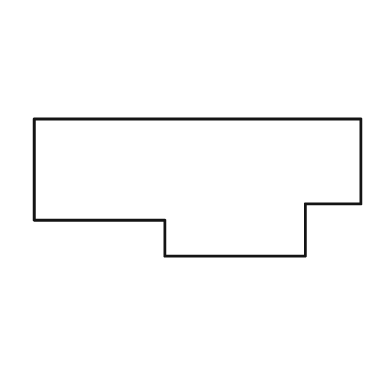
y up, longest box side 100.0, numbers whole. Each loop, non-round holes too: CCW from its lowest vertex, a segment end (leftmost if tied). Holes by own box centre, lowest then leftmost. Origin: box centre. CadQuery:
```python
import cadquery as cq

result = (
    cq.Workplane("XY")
    .moveTo(-10.0, -21.0)
    .lineTo(33.0, -21.0)
    .lineTo(33.0, -5.0)
    .lineTo(50.0, -5.0)
    .lineTo(50.0, 21.0)
    .lineTo(-50.0, 21.0)
    .lineTo(-50.0, -10.0)
    .lineTo(-10.0, -10.0)
    .close()
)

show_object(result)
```